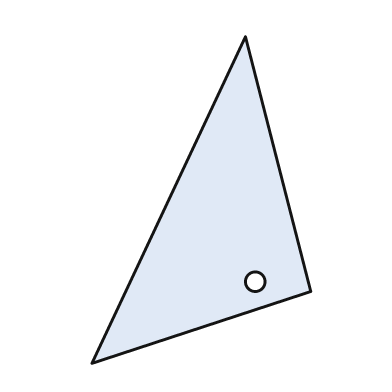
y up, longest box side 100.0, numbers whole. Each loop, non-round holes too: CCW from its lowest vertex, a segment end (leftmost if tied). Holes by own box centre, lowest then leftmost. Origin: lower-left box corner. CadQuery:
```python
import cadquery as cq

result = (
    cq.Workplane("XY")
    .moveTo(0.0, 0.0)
    .lineTo(67.0, 22.0)
    .lineTo(47.0, 100.0)
    .close()
    .moveTo(50.0, 25.0)
    .circle(3.0)
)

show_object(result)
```